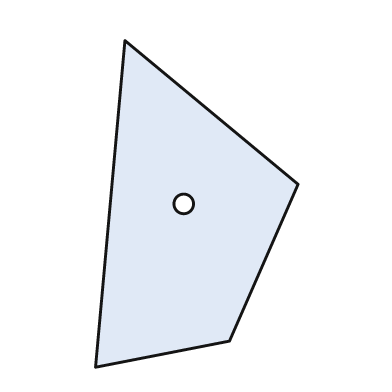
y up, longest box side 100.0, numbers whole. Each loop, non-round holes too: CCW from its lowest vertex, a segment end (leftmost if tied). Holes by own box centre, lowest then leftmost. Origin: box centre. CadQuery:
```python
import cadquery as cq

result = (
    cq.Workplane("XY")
    .moveTo(-31.0, -50.0)
    .lineTo(10.0, -42.0)
    .lineTo(31.0, 6.0)
    .lineTo(-22.0, 50.0)
    .close()
    .moveTo(-4.0, 0.0)
    .circle(3.0)
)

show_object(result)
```